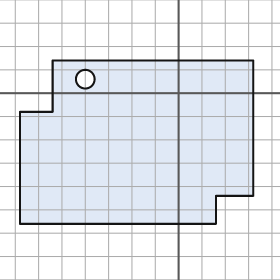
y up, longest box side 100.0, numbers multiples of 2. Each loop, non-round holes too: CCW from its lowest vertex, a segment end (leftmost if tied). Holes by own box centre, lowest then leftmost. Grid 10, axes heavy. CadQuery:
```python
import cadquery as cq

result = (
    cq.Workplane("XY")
    .moveTo(-68.0, -56.0)
    .lineTo(16.0, -56.0)
    .lineTo(16.0, -44.0)
    .lineTo(32.0, -44.0)
    .lineTo(32.0, 14.0)
    .lineTo(-54.0, 14.0)
    .lineTo(-54.0, -8.0)
    .lineTo(-68.0, -8.0)
    .close()
    .moveTo(-40.0, 6.0)
    .circle(4.0)
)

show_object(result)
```